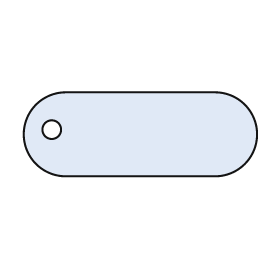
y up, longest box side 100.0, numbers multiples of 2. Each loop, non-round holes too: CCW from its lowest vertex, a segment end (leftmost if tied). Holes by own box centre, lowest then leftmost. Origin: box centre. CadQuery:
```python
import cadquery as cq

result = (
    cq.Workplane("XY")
    .moveTo(-32.0, -18.0)
    .lineTo(32.0, -18.0)
    .threePointArc((50.0, 0.0), (32.0, 18.0))
    .lineTo(-32.0, 18.0)
    .threePointArc((-50.0, 0.0), (-32.0, -18.0))
    .close()
    .moveTo(-38.0, 2.0)
    .circle(4.0)
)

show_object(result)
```